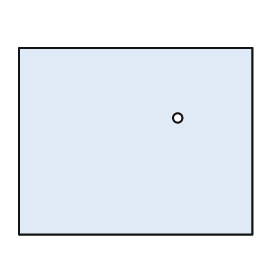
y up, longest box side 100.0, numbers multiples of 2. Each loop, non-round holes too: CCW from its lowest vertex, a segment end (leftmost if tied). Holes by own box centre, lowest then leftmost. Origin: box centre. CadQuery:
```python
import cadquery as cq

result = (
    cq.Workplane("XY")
    .moveTo(-50.0, -40.0)
    .lineTo(50.0, -40.0)
    .lineTo(50.0, 40.0)
    .lineTo(-50.0, 40.0)
    .close()
    .moveTo(18.0, 10.0)
    .circle(2.0)
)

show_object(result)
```